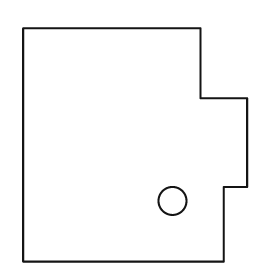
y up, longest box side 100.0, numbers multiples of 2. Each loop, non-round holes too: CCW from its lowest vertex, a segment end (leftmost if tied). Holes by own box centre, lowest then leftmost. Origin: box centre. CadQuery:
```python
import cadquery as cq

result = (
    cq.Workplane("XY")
    .moveTo(-48.0, -50.0)
    .lineTo(38.0, -50.0)
    .lineTo(38.0, -18.0)
    .lineTo(48.0, -18.0)
    .lineTo(48.0, 20.0)
    .lineTo(28.0, 20.0)
    .lineTo(28.0, 50.0)
    .lineTo(-48.0, 50.0)
    .close()
    .moveTo(16.0, -24.0)
    .circle(6.0)
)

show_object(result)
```